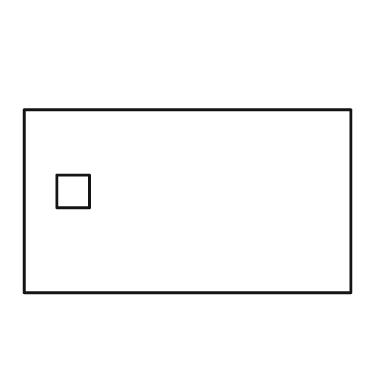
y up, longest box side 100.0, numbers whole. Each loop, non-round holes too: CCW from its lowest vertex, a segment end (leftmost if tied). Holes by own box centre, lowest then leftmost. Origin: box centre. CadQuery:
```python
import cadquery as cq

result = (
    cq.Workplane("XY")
    .moveTo(-50.0, -28.0)
    .lineTo(50.0, -28.0)
    .lineTo(50.0, 28.0)
    .lineTo(-50.0, 28.0)
    .close()
    .moveTo(-40.0, -2.0)
    .lineTo(-30.0, -2.0)
    .lineTo(-30.0, 8.0)
    .lineTo(-40.0, 8.0)
    .close()
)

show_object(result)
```